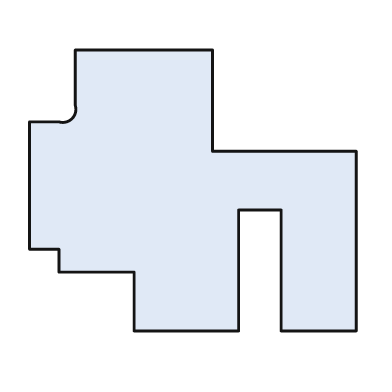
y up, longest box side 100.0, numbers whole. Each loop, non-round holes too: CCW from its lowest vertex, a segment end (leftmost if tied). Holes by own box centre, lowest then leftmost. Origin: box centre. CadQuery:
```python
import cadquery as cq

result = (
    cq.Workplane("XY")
    .moveTo(-18.0, -43.0)
    .lineTo(14.0, -43.0)
    .lineTo(14.0, -6.0)
    .lineTo(27.0, -6.0)
    .lineTo(27.0, -43.0)
    .lineTo(50.0, -43.0)
    .lineTo(50.0, 12.0)
    .lineTo(6.0, 12.0)
    .lineTo(6.0, 43.0)
    .lineTo(-36.0, 43.0)
    .lineTo(-36.0, 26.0)
    .threePointArc((-37.0, 22.0), (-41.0, 21.0))
    .lineTo(-50.0, 21.0)
    .lineTo(-50.0, -18.0)
    .lineTo(-41.0, -18.0)
    .lineTo(-41.0, -25.0)
    .lineTo(-18.0, -25.0)
    .close()
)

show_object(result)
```